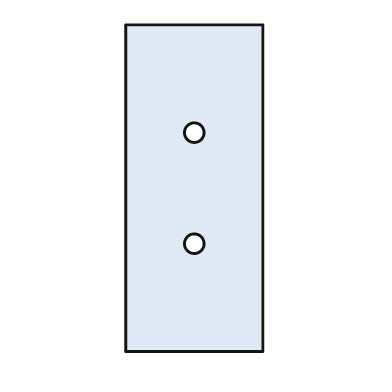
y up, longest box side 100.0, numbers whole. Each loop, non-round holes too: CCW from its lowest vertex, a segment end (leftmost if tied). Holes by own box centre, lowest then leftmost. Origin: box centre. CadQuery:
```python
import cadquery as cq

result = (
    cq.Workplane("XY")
    .moveTo(-21.0, -50.0)
    .lineTo(21.0, -50.0)
    .lineTo(21.0, 50.0)
    .lineTo(-21.0, 50.0)
    .close()
    .moveTo(0.0, -17.0)
    .circle(3.0)
    .moveTo(0.0, 17.0)
    .circle(3.0)
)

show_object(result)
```